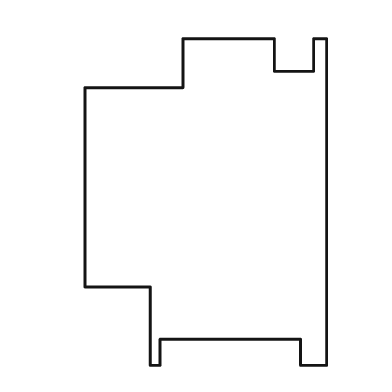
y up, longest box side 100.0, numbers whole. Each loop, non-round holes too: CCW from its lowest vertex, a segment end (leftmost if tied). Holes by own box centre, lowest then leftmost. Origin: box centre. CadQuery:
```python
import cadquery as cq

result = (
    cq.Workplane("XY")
    .moveTo(-17.0, -50.0)
    .lineTo(-14.0, -50.0)
    .lineTo(-14.0, -42.0)
    .lineTo(29.0, -42.0)
    .lineTo(29.0, -50.0)
    .lineTo(37.0, -50.0)
    .lineTo(37.0, 50.0)
    .lineTo(33.0, 50.0)
    .lineTo(33.0, 40.0)
    .lineTo(21.0, 40.0)
    .lineTo(21.0, 50.0)
    .lineTo(-7.0, 50.0)
    .lineTo(-7.0, 35.0)
    .lineTo(-37.0, 35.0)
    .lineTo(-37.0, -26.0)
    .lineTo(-17.0, -26.0)
    .close()
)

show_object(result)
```